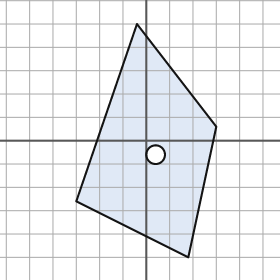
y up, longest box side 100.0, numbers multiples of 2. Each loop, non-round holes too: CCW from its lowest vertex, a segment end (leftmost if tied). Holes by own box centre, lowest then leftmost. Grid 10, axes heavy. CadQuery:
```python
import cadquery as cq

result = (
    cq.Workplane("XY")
    .moveTo(18.0, -50.0)
    .lineTo(30.0, 6.0)
    .lineTo(-4.0, 50.0)
    .lineTo(-30.0, -26.0)
    .close()
    .moveTo(4.0, -6.0)
    .circle(4.0)
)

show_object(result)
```